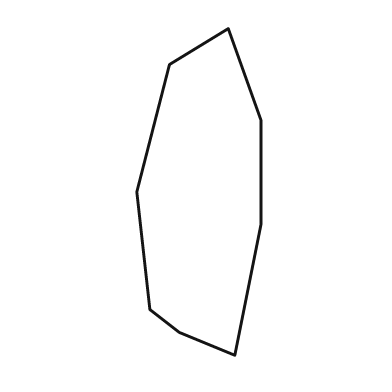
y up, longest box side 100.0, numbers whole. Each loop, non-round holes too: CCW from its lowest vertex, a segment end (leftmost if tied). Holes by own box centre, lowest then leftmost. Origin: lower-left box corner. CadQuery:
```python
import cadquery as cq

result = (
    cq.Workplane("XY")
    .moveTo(30.0, 0.0)
    .lineTo(38.0, 40.0)
    .lineTo(38.0, 72.0)
    .lineTo(28.0, 100.0)
    .lineTo(10.0, 89.0)
    .lineTo(0.0, 50.0)
    .lineTo(4.0, 14.0)
    .lineTo(13.0, 7.0)
    .close()
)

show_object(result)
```